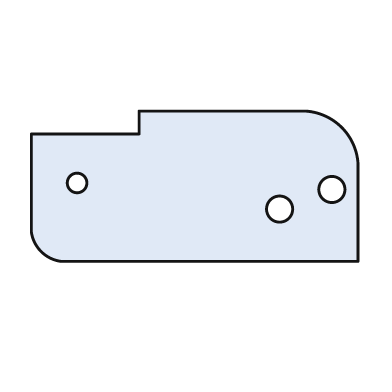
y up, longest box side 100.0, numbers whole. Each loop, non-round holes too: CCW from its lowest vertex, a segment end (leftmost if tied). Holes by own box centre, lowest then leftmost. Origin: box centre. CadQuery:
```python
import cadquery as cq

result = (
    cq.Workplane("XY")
    .moveTo(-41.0, -23.0)
    .lineTo(50.0, -23.0)
    .lineTo(50.0, 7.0)
    .threePointArc((45.0, 18.0), (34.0, 23.0))
    .lineTo(-17.0, 23.0)
    .lineTo(-17.0, 16.0)
    .lineTo(-50.0, 16.0)
    .lineTo(-50.0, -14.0)
    .threePointArc((-47.0, -20.0), (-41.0, -23.0))
    .close()
    .moveTo(26.0, -7.0)
    .circle(4.0)
    .moveTo(42.0, -1.0)
    .circle(4.0)
    .moveTo(-36.0, 1.0)
    .circle(3.0)
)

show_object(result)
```